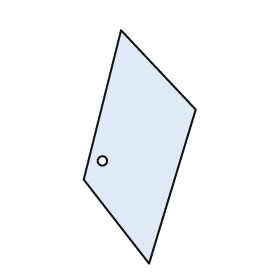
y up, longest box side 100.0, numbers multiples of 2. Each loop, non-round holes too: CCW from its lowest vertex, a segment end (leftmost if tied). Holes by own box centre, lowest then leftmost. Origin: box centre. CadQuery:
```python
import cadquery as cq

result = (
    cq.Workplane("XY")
    .moveTo(4.0, -50.0)
    .lineTo(24.0, 16.0)
    .lineTo(-8.0, 50.0)
    .lineTo(-24.0, -14.0)
    .close()
    .moveTo(-16.0, -6.0)
    .circle(2.0)
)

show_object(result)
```